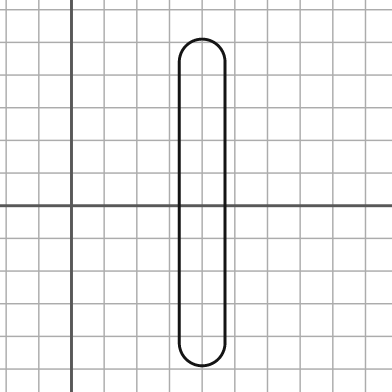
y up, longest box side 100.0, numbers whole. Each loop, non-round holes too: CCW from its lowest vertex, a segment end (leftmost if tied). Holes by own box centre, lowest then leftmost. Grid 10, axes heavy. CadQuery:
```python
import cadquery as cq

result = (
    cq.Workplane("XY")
    .moveTo(33.0, -42.0)
    .threePointArc((40.0, -49.0), (47.0, -42.0))
    .lineTo(47.0, 44.0)
    .threePointArc((40.0, 51.0), (33.0, 44.0))
    .close()
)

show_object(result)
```